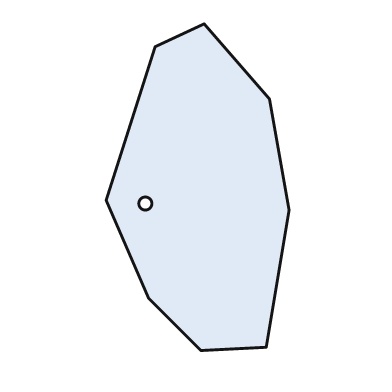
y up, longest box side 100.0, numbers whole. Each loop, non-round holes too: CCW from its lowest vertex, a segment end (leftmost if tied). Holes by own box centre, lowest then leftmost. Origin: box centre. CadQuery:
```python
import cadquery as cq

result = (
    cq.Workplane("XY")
    .moveTo(1.0, -50.0)
    .lineTo(21.0, -49.0)
    .lineTo(28.0, -7.0)
    .lineTo(22.0, 27.0)
    .lineTo(2.0, 50.0)
    .lineTo(-13.0, 43.0)
    .lineTo(-28.0, -4.0)
    .lineTo(-15.0, -34.0)
    .close()
    .moveTo(-16.0, -5.0)
    .circle(2.0)
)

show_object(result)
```